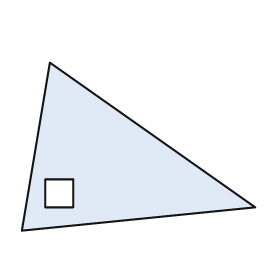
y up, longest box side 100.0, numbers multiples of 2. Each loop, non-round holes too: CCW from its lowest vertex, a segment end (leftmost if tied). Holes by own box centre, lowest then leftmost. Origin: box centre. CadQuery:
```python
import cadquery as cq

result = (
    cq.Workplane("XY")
    .moveTo(-50.0, -36.0)
    .lineTo(50.0, -26.0)
    .lineTo(-38.0, 36.0)
    .close()
    .moveTo(-40.0, -26.0)
    .lineTo(-28.0, -26.0)
    .lineTo(-28.0, -14.0)
    .lineTo(-40.0, -14.0)
    .close()
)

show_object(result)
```